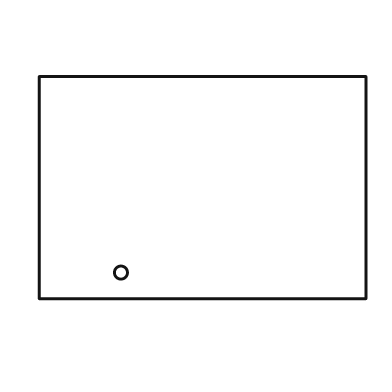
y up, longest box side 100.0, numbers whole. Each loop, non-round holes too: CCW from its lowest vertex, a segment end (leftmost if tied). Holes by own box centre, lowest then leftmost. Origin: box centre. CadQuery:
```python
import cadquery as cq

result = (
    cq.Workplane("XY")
    .moveTo(-50.0, -34.0)
    .lineTo(50.0, -34.0)
    .lineTo(50.0, 34.0)
    .lineTo(-50.0, 34.0)
    .close()
    .moveTo(-25.0, -26.0)
    .circle(2.0)
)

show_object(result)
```